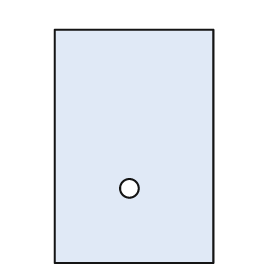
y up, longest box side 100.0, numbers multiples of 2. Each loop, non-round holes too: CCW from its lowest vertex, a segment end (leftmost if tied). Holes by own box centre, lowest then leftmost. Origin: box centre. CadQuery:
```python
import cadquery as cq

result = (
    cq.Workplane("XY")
    .moveTo(-34.0, -50.0)
    .lineTo(34.0, -50.0)
    .lineTo(34.0, 50.0)
    .lineTo(-34.0, 50.0)
    .close()
    .moveTo(-2.0, -18.0)
    .circle(4.0)
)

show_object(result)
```